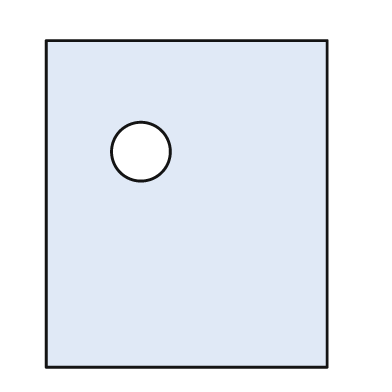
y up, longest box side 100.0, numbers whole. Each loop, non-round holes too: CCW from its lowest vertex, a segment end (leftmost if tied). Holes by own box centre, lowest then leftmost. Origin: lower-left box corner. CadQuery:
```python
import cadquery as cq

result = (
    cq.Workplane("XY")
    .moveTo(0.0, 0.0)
    .lineTo(86.0, 0.0)
    .lineTo(86.0, 100.0)
    .lineTo(0.0, 100.0)
    .close()
    .moveTo(29.0, 66.0)
    .circle(9.0)
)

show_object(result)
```